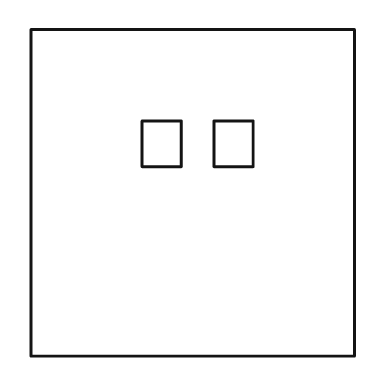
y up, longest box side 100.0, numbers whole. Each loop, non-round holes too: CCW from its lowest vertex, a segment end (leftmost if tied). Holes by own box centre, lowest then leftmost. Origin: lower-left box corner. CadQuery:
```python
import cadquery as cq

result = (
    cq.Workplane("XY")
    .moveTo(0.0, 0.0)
    .lineTo(99.0, 0.0)
    .lineTo(99.0, 100.0)
    .lineTo(0.0, 100.0)
    .close()
    .moveTo(34.0, 58.0)
    .lineTo(46.0, 58.0)
    .lineTo(46.0, 72.0)
    .lineTo(34.0, 72.0)
    .close()
    .moveTo(56.0, 58.0)
    .lineTo(68.0, 58.0)
    .lineTo(68.0, 72.0)
    .lineTo(56.0, 72.0)
    .close()
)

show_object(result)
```